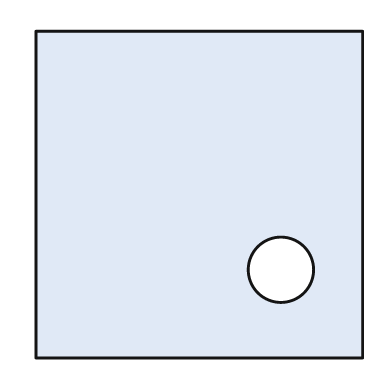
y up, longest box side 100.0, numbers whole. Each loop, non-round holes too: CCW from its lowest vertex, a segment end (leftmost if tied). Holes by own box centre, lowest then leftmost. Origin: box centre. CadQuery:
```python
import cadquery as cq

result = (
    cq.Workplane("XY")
    .moveTo(-50.0, -50.0)
    .lineTo(50.0, -50.0)
    .lineTo(50.0, 50.0)
    .lineTo(-50.0, 50.0)
    .close()
    .moveTo(25.0, -23.0)
    .circle(10.0)
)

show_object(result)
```